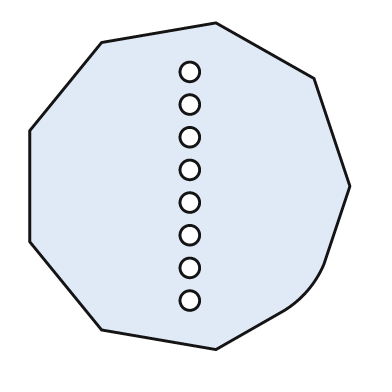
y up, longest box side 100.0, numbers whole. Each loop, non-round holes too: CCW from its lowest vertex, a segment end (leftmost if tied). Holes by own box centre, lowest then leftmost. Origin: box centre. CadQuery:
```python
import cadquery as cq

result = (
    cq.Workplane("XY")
    .moveTo(8.0, -50.0)
    .lineTo(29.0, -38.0)
    .threePointArc((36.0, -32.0), (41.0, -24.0))
    .lineTo(49.0, 0.0)
    .lineTo(38.0, 33.0)
    .lineTo(8.0, 50.0)
    .lineTo(-27.0, 44.0)
    .lineTo(-49.0, 17.0)
    .lineTo(-49.0, -17.0)
    .lineTo(-27.0, -44.0)
    .close()
    .moveTo(0.0, -35.0)
    .circle(3.0)
    .moveTo(0.0, -25.0)
    .circle(3.0)
    .moveTo(0.0, -15.0)
    .circle(3.0)
    .moveTo(0.0, -5.0)
    .circle(3.0)
    .moveTo(0.0, 5.0)
    .circle(3.0)
    .moveTo(0.0, 15.0)
    .circle(3.0)
    .moveTo(0.0, 25.0)
    .circle(3.0)
    .moveTo(0.0, 35.0)
    .circle(3.0)
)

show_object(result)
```